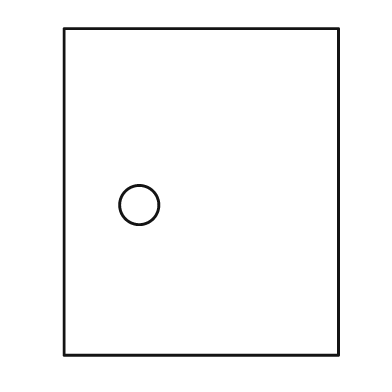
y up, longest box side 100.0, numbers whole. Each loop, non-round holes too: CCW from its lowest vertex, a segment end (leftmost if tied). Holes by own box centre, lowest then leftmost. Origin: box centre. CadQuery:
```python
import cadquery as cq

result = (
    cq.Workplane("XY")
    .moveTo(-42.0, -50.0)
    .lineTo(42.0, -50.0)
    .lineTo(42.0, 50.0)
    .lineTo(-42.0, 50.0)
    .close()
    .moveTo(-19.0, -4.0)
    .circle(6.0)
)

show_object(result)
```